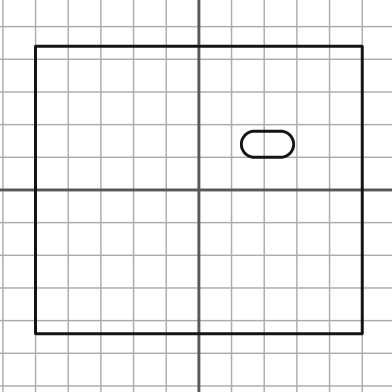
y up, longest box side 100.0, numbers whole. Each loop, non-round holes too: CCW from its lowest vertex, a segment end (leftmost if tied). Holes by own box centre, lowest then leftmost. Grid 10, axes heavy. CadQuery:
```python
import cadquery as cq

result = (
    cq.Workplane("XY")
    .moveTo(-50.0, -44.0)
    .lineTo(50.0, -44.0)
    .lineTo(50.0, 44.0)
    .lineTo(-50.0, 44.0)
    .close()
    .moveTo(17.0, 10.0)
    .lineTo(25.0, 10.0)
    .threePointArc((29.0, 14.0), (25.0, 18.0))
    .lineTo(17.0, 18.0)
    .threePointArc((13.0, 14.0), (17.0, 10.0))
    .close()
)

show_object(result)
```